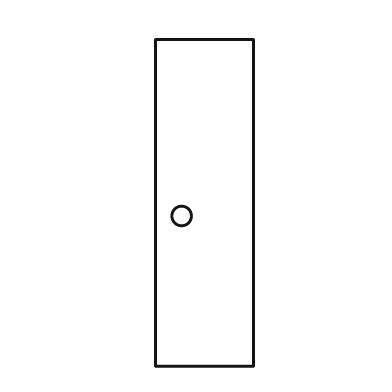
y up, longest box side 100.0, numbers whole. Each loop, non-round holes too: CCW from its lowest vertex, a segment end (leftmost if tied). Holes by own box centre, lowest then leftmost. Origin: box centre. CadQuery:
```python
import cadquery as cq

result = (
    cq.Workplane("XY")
    .moveTo(-15.0, -50.0)
    .lineTo(15.0, -50.0)
    .lineTo(15.0, 50.0)
    .lineTo(-15.0, 50.0)
    .close()
    .moveTo(-7.0, -4.0)
    .circle(3.0)
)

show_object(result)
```